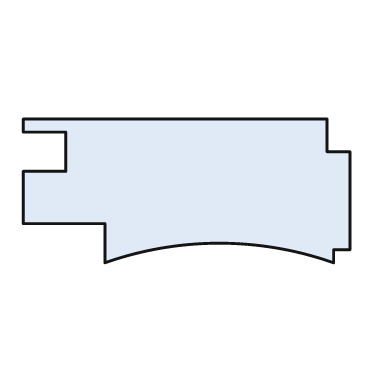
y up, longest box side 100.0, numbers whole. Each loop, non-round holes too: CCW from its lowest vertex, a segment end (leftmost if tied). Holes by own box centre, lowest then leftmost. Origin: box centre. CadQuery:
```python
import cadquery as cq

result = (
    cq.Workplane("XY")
    .moveTo(-25.0, -22.0)
    .threePointArc((10.0, -16.0), (45.0, -22.0))
    .lineTo(45.0, -18.0)
    .lineTo(50.0, -18.0)
    .lineTo(50.0, 12.0)
    .lineTo(43.0, 12.0)
    .lineTo(43.0, 22.0)
    .lineTo(-50.0, 22.0)
    .lineTo(-50.0, 18.0)
    .lineTo(-37.0, 18.0)
    .lineTo(-37.0, 6.0)
    .lineTo(-50.0, 6.0)
    .lineTo(-50.0, -10.0)
    .lineTo(-25.0, -10.0)
    .close()
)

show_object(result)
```